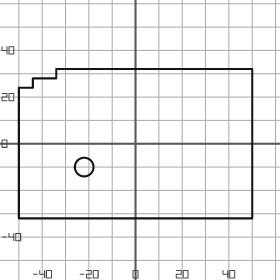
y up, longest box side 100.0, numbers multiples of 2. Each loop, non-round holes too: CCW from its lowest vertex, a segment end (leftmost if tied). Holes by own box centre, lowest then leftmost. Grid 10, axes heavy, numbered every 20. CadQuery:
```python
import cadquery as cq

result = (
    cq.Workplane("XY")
    .moveTo(-50.0, -32.0)
    .lineTo(50.0, -32.0)
    .lineTo(50.0, 32.0)
    .lineTo(-34.0, 32.0)
    .lineTo(-34.0, 28.0)
    .lineTo(-44.0, 28.0)
    .lineTo(-44.0, 24.0)
    .lineTo(-50.0, 24.0)
    .close()
    .moveTo(-22.0, -10.0)
    .circle(4.0)
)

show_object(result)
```